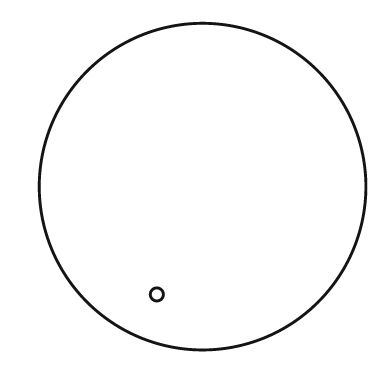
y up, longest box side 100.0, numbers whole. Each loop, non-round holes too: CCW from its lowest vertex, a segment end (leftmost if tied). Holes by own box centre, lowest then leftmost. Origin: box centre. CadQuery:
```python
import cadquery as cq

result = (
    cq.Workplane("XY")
    .moveTo(0.0, 0.0)
    .circle(50.0)
    .moveTo(-14.0, -33.0)
    .circle(2.0)
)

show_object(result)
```